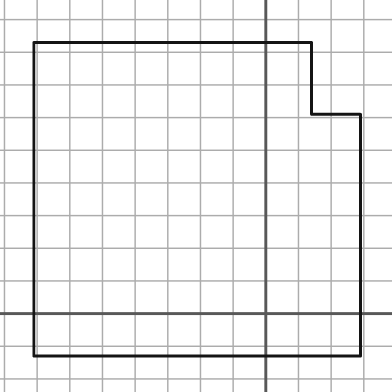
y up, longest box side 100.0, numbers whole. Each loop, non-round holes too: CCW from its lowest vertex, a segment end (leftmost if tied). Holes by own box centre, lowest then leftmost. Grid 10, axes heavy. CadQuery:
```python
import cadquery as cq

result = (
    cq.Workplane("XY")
    .moveTo(-71.0, -13.0)
    .lineTo(29.0, -13.0)
    .lineTo(29.0, 61.0)
    .lineTo(14.0, 61.0)
    .lineTo(14.0, 83.0)
    .lineTo(-71.0, 83.0)
    .close()
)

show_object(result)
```